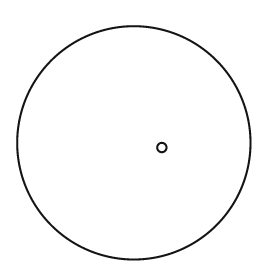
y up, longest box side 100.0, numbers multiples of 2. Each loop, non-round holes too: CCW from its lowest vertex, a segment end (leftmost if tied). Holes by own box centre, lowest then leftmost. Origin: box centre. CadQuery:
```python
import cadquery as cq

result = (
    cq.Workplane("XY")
    .moveTo(0.0, 0.0)
    .circle(50.0)
    .moveTo(12.0, -2.0)
    .circle(2.0)
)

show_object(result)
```